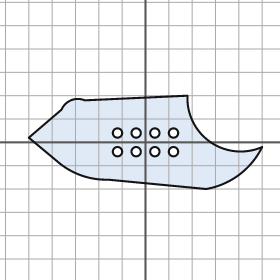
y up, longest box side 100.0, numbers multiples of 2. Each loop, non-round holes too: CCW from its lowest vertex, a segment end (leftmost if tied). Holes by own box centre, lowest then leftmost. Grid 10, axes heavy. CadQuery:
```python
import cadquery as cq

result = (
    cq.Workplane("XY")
    .moveTo(26.0, -20.0)
    .threePointArc((40.0, -14.0), (50.0, -2.0))
    .threePointArc((28.0, 0.0), (18.0, 20.0))
    .lineTo(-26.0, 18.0)
    .threePointArc((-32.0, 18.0), (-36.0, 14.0))
    .lineTo(-50.0, 2.0)
    .lineTo(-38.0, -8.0)
    .threePointArc((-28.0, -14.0), (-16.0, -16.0))
    .close()
    .moveTo(-12.0, -4.0)
    .circle(2.0)
    .moveTo(-4.0, -4.0)
    .circle(2.0)
    .moveTo(4.0, -4.0)
    .circle(2.0)
    .moveTo(12.0, -4.0)
    .circle(2.0)
    .moveTo(-12.0, 4.0)
    .circle(2.0)
    .moveTo(-4.0, 4.0)
    .circle(2.0)
    .moveTo(4.0, 4.0)
    .circle(2.0)
    .moveTo(12.0, 4.0)
    .circle(2.0)
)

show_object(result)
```